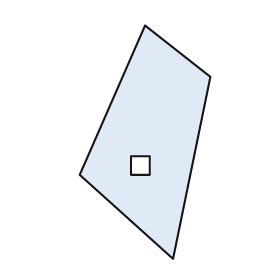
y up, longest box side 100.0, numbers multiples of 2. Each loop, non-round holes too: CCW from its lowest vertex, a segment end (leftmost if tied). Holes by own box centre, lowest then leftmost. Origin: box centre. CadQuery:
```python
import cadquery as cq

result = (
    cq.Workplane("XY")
    .moveTo(12.0, -50.0)
    .lineTo(28.0, 28.0)
    .lineTo(0.0, 50.0)
    .lineTo(-28.0, -14.0)
    .close()
    .moveTo(-6.0, -14.0)
    .lineTo(2.0, -14.0)
    .lineTo(2.0, -6.0)
    .lineTo(-6.0, -6.0)
    .close()
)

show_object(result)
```